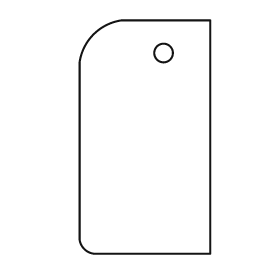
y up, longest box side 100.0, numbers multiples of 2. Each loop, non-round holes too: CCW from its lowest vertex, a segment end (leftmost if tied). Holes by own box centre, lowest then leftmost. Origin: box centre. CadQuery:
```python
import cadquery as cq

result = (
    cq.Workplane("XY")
    .moveTo(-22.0, -50.0)
    .lineTo(28.0, -50.0)
    .lineTo(28.0, 50.0)
    .lineTo(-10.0, 50.0)
    .threePointArc((-22.0, 44.0), (-28.0, 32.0))
    .lineTo(-28.0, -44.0)
    .threePointArc((-26.0, -48.0), (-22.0, -50.0))
    .close()
    .moveTo(8.0, 36.0)
    .circle(4.0)
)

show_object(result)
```